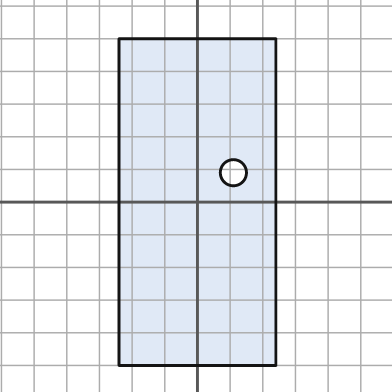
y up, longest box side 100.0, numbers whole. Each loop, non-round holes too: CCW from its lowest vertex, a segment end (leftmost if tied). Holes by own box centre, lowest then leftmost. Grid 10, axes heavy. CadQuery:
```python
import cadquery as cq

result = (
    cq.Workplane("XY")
    .moveTo(-24.0, -50.0)
    .lineTo(24.0, -50.0)
    .lineTo(24.0, 50.0)
    .lineTo(-24.0, 50.0)
    .close()
    .moveTo(11.0, 9.0)
    .circle(4.0)
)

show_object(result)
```